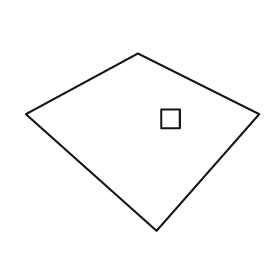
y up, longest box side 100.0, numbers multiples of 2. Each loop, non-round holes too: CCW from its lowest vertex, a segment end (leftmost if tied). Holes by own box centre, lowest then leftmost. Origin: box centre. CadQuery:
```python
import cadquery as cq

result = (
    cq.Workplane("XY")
    .moveTo(6.0, -38.0)
    .lineTo(50.0, 12.0)
    .lineTo(-2.0, 38.0)
    .lineTo(-50.0, 12.0)
    .close()
    .moveTo(8.0, 6.0)
    .lineTo(16.0, 6.0)
    .lineTo(16.0, 14.0)
    .lineTo(8.0, 14.0)
    .close()
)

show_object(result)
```